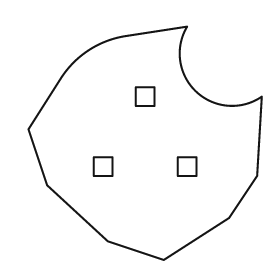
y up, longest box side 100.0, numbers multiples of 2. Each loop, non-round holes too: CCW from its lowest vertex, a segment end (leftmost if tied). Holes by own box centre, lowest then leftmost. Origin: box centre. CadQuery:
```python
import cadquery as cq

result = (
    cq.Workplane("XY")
    .moveTo(8.0, -50.0)
    .lineTo(36.0, -32.0)
    .lineTo(48.0, -14.0)
    .lineTo(50.0, 20.0)
    .threePointArc((22.0, 22.0), (18.0, 50.0))
    .lineTo(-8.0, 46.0)
    .threePointArc((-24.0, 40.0), (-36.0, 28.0))
    .lineTo(-50.0, 6.0)
    .lineTo(-42.0, -18.0)
    .lineTo(-16.0, -42.0)
    .close()
    .moveTo(-22.0, -14.0)
    .lineTo(-14.0, -14.0)
    .lineTo(-14.0, -6.0)
    .lineTo(-22.0, -6.0)
    .close()
    .moveTo(14.0, -14.0)
    .lineTo(22.0, -14.0)
    .lineTo(22.0, -6.0)
    .lineTo(14.0, -6.0)
    .close()
    .moveTo(-4.0, 16.0)
    .lineTo(4.0, 16.0)
    .lineTo(4.0, 24.0)
    .lineTo(-4.0, 24.0)
    .close()
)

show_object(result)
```